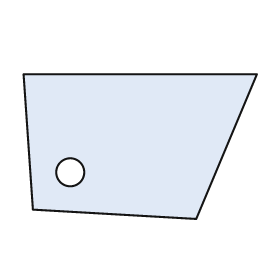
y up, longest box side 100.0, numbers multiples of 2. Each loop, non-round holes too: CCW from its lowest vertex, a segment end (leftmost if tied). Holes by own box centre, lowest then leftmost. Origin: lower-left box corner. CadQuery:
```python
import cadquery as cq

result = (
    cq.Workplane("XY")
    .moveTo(74.0, 0.0)
    .lineTo(100.0, 62.0)
    .lineTo(0.0, 62.0)
    .lineTo(4.0, 4.0)
    .close()
    .moveTo(20.0, 20.0)
    .circle(6.0)
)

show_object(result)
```